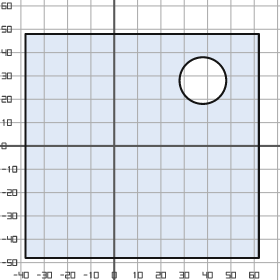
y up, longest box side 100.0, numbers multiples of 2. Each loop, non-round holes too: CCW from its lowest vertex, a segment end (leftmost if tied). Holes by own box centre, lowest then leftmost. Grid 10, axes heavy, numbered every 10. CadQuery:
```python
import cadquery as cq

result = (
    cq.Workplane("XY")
    .moveTo(-38.0, -48.0)
    .lineTo(62.0, -48.0)
    .lineTo(62.0, 48.0)
    .lineTo(-38.0, 48.0)
    .close()
    .moveTo(38.0, 28.0)
    .circle(10.0)
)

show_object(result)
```